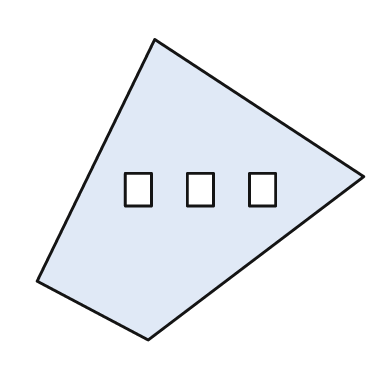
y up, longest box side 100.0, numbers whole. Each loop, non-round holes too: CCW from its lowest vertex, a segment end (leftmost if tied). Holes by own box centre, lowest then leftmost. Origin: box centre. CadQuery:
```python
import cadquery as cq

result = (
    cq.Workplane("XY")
    .moveTo(-16.0, -46.0)
    .lineTo(50.0, 4.0)
    .lineTo(-14.0, 46.0)
    .lineTo(-50.0, -28.0)
    .close()
    .moveTo(-23.0, -5.0)
    .lineTo(-15.0, -5.0)
    .lineTo(-15.0, 5.0)
    .lineTo(-23.0, 5.0)
    .close()
    .moveTo(-4.0, -5.0)
    .lineTo(4.0, -5.0)
    .lineTo(4.0, 5.0)
    .lineTo(-4.0, 5.0)
    .close()
    .moveTo(15.0, -5.0)
    .lineTo(23.0, -5.0)
    .lineTo(23.0, 5.0)
    .lineTo(15.0, 5.0)
    .close()
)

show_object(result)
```